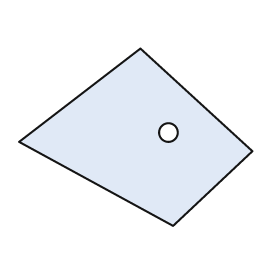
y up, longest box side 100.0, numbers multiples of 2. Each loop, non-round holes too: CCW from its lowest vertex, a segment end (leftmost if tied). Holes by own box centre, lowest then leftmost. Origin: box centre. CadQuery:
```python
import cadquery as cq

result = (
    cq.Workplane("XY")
    .moveTo(16.0, -38.0)
    .lineTo(50.0, -6.0)
    .lineTo(2.0, 38.0)
    .lineTo(-50.0, -2.0)
    .close()
    .moveTo(14.0, 2.0)
    .circle(4.0)
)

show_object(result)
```